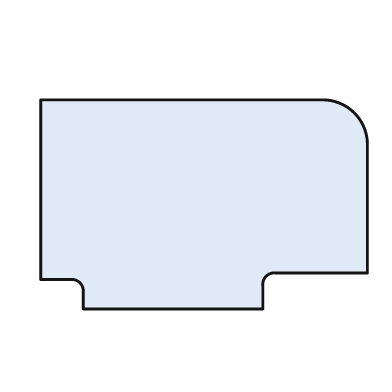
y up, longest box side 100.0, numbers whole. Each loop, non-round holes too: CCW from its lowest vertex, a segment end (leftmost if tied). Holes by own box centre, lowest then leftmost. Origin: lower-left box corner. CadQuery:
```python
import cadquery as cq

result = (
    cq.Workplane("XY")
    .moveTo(13.0, 0.0)
    .lineTo(68.0, 0.0)
    .lineTo(68.0, 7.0)
    .threePointArc((69.0, 10.0), (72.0, 11.0))
    .lineTo(100.0, 11.0)
    .lineTo(100.0, 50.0)
    .threePointArc((96.0, 60.0), (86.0, 64.0))
    .lineTo(0.0, 64.0)
    .lineTo(0.0, 9.0)
    .lineTo(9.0, 9.0)
    .threePointArc((12.0, 8.0), (13.0, 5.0))
    .close()
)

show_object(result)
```